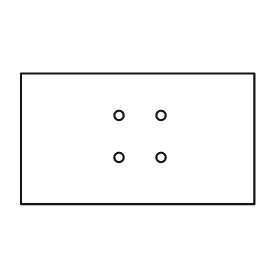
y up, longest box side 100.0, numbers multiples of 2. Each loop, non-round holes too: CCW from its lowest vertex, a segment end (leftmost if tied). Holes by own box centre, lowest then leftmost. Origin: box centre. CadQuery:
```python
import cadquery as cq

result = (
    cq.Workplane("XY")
    .moveTo(-50.0, -28.0)
    .lineTo(50.0, -28.0)
    .lineTo(50.0, 28.0)
    .lineTo(-50.0, 28.0)
    .close()
    .moveTo(-8.0, -8.0)
    .circle(2.0)
    .moveTo(10.0, -8.0)
    .circle(2.0)
    .moveTo(-8.0, 10.0)
    .circle(2.0)
    .moveTo(10.0, 10.0)
    .circle(2.0)
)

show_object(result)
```